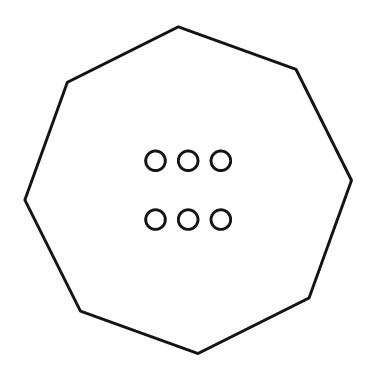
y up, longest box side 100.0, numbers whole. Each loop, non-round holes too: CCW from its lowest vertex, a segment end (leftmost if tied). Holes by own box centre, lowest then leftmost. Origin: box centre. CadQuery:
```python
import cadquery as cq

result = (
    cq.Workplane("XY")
    .moveTo(3.0, -50.0)
    .lineTo(37.0, -33.0)
    .lineTo(50.0, 3.0)
    .lineTo(33.0, 37.0)
    .lineTo(-3.0, 50.0)
    .lineTo(-37.0, 33.0)
    .lineTo(-50.0, -3.0)
    .lineTo(-33.0, -37.0)
    .close()
    .moveTo(-10.0, -9.0)
    .circle(3.0)
    .moveTo(0.0, -9.0)
    .circle(3.0)
    .moveTo(10.0, -9.0)
    .circle(3.0)
    .moveTo(-10.0, 9.0)
    .circle(3.0)
    .moveTo(0.0, 9.0)
    .circle(3.0)
    .moveTo(10.0, 9.0)
    .circle(3.0)
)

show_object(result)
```